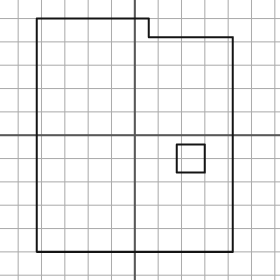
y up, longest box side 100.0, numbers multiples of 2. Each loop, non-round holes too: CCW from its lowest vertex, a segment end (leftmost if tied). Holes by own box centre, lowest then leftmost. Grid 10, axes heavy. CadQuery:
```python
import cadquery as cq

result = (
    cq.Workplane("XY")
    .moveTo(-42.0, -50.0)
    .lineTo(42.0, -50.0)
    .lineTo(42.0, 42.0)
    .lineTo(6.0, 42.0)
    .lineTo(6.0, 50.0)
    .lineTo(-42.0, 50.0)
    .close()
    .moveTo(18.0, -16.0)
    .lineTo(30.0, -16.0)
    .lineTo(30.0, -4.0)
    .lineTo(18.0, -4.0)
    .close()
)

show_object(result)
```